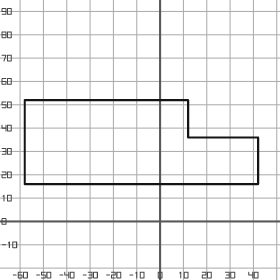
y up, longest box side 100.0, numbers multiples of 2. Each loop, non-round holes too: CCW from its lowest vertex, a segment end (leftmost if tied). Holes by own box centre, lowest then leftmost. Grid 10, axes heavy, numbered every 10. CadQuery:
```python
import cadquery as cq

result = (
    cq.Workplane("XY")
    .moveTo(-58.0, 16.0)
    .lineTo(42.0, 16.0)
    .lineTo(42.0, 36.0)
    .lineTo(12.0, 36.0)
    .lineTo(12.0, 52.0)
    .lineTo(-58.0, 52.0)
    .close()
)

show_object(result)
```